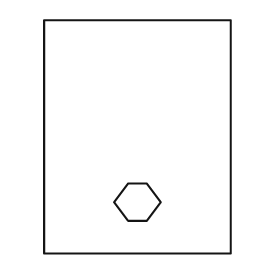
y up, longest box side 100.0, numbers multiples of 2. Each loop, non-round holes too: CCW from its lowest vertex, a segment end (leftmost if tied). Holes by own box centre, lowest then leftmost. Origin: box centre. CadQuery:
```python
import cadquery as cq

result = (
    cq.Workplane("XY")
    .moveTo(-40.0, -50.0)
    .lineTo(40.0, -50.0)
    .lineTo(40.0, 50.0)
    .lineTo(-40.0, 50.0)
    .close()
    .moveTo(-4.0, -36.0)
    .lineTo(4.0, -36.0)
    .lineTo(10.0, -28.0)
    .lineTo(4.0, -20.0)
    .lineTo(-4.0, -20.0)
    .lineTo(-10.0, -28.0)
    .close()
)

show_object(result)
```